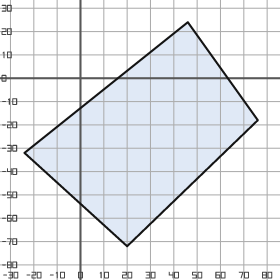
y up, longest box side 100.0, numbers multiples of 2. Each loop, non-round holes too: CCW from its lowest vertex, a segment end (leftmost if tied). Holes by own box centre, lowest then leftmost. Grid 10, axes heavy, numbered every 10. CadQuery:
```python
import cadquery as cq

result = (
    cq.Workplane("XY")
    .moveTo(20.0, -72.0)
    .lineTo(76.0, -18.0)
    .lineTo(46.0, 24.0)
    .lineTo(-24.0, -32.0)
    .close()
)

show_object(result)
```